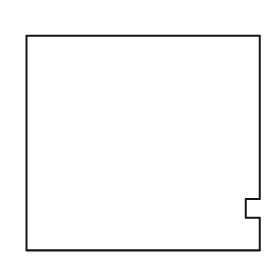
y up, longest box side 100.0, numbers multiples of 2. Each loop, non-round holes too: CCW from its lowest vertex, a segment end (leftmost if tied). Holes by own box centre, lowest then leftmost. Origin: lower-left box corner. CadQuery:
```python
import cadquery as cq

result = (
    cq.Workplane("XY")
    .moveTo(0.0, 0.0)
    .lineTo(100.0, 0.0)
    .lineTo(100.0, 14.0)
    .lineTo(94.0, 14.0)
    .lineTo(94.0, 22.0)
    .lineTo(100.0, 22.0)
    .lineTo(100.0, 92.0)
    .lineTo(0.0, 92.0)
    .close()
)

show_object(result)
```